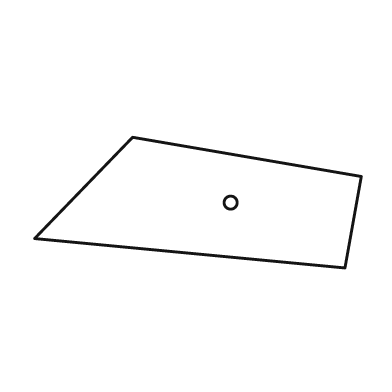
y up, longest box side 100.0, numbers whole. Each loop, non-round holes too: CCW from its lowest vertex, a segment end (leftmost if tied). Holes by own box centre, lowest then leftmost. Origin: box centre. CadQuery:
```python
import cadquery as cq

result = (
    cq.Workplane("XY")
    .moveTo(45.0, -20.0)
    .lineTo(50.0, 8.0)
    .lineTo(-20.0, 20.0)
    .lineTo(-50.0, -11.0)
    .close()
    .moveTo(10.0, 0.0)
    .circle(2.0)
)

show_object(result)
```